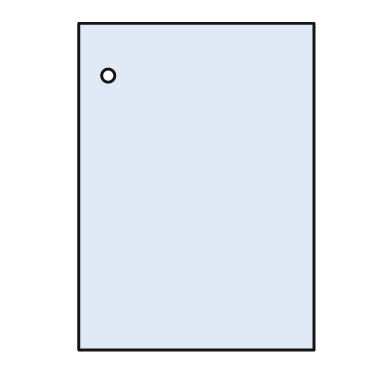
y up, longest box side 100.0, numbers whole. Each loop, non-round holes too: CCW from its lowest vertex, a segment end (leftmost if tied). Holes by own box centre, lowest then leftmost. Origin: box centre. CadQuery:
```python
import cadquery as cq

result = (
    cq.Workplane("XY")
    .moveTo(-36.0, -50.0)
    .lineTo(36.0, -50.0)
    .lineTo(36.0, 50.0)
    .lineTo(-36.0, 50.0)
    .close()
    .moveTo(-27.0, 34.0)
    .circle(2.0)
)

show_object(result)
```